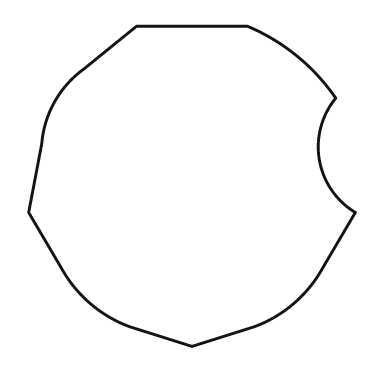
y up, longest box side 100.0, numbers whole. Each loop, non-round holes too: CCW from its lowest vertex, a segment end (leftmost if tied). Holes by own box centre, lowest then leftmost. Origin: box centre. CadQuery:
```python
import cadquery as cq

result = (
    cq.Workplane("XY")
    .moveTo(0.0, -49.0)
    .lineTo(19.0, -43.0)
    .threePointArc((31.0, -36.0), (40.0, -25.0))
    .lineTo(50.0, -8.0)
    .threePointArc((39.0, 8.0), (44.0, 27.0))
    .threePointArc((32.0, 40.0), (17.0, 49.0))
    .lineTo(-17.0, 49.0)
    .lineTo(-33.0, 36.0)
    .threePointArc((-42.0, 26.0), (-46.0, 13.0))
    .lineTo(-50.0, -8.0)
    .lineTo(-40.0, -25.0)
    .threePointArc((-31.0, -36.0), (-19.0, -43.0))
    .close()
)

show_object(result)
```